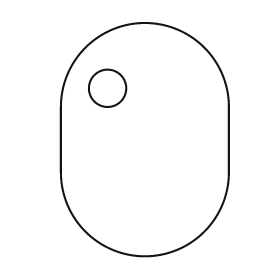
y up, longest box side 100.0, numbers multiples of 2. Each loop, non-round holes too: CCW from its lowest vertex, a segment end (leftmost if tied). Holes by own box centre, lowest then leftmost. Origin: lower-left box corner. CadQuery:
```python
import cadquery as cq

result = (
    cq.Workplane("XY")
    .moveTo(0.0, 36.0)
    .threePointArc((36.0, 0.0), (72.0, 36.0))
    .lineTo(72.0, 64.0)
    .threePointArc((36.0, 100.0), (0.0, 64.0))
    .close()
    .moveTo(20.0, 72.0)
    .circle(8.0)
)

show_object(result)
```